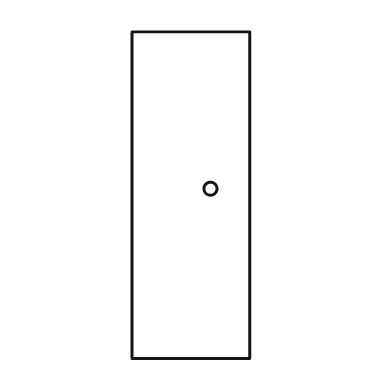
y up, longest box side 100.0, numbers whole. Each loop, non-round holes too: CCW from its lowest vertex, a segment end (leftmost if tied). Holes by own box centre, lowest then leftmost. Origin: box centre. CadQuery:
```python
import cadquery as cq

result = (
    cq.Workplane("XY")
    .moveTo(-18.0, -50.0)
    .lineTo(18.0, -50.0)
    .lineTo(18.0, 50.0)
    .lineTo(-18.0, 50.0)
    .close()
    .moveTo(6.0, 2.0)
    .circle(2.0)
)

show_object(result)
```